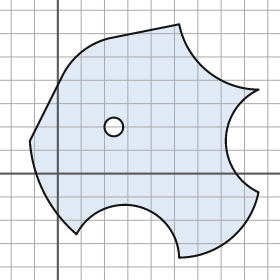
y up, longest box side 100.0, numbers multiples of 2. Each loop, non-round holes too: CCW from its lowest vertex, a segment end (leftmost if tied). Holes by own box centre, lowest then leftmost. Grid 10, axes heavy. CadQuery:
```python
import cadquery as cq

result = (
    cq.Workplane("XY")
    .moveTo(52.0, -36.0)
    .threePointArc((74.0, -28.0), (86.0, -8.0))
    .threePointArc((72.0, 14.0), (86.0, 36.0))
    .threePointArc((64.0, 44.0), (52.0, 64.0))
    .lineTo(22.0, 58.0)
    .threePointArc((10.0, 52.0), (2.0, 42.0))
    .lineTo(-12.0, 14.0)
    .threePointArc((-6.0, -8.0), (8.0, -26.0))
    .threePointArc((34.0, -14.0), (52.0, -36.0))
    .close()
    .moveTo(24.0, 20.0)
    .circle(4.0)
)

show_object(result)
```